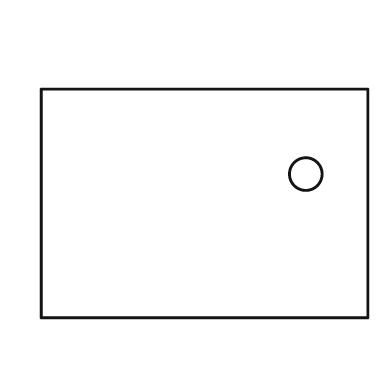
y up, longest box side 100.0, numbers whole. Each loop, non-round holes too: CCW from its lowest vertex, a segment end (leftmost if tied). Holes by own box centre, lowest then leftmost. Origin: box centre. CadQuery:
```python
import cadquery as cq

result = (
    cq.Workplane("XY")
    .moveTo(-50.0, -35.0)
    .lineTo(50.0, -35.0)
    .lineTo(50.0, 35.0)
    .lineTo(-50.0, 35.0)
    .close()
    .moveTo(31.0, 9.0)
    .circle(5.0)
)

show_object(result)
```